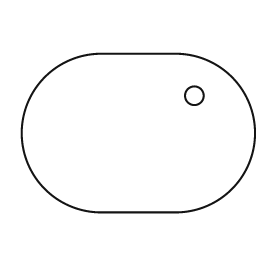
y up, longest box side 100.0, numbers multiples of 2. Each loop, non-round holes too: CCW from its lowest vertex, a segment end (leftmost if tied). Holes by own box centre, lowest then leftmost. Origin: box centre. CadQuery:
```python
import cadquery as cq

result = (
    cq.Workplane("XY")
    .moveTo(-16.0, -34.0)
    .lineTo(16.0, -34.0)
    .threePointArc((50.0, 0.0), (16.0, 34.0))
    .lineTo(-16.0, 34.0)
    .threePointArc((-50.0, 0.0), (-16.0, -34.0))
    .close()
    .moveTo(24.0, 16.0)
    .circle(4.0)
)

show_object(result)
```